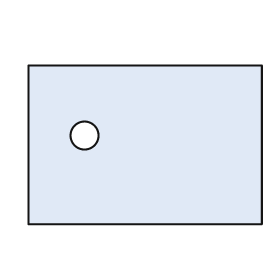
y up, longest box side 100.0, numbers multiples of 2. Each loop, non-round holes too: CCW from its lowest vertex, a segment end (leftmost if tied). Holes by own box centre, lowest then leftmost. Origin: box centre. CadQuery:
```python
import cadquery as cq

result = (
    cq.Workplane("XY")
    .moveTo(-50.0, -34.0)
    .lineTo(50.0, -34.0)
    .lineTo(50.0, 34.0)
    .lineTo(-50.0, 34.0)
    .close()
    .moveTo(-26.0, 4.0)
    .circle(6.0)
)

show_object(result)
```